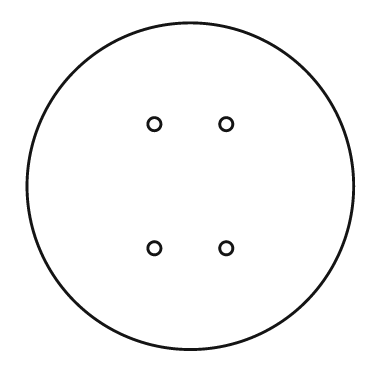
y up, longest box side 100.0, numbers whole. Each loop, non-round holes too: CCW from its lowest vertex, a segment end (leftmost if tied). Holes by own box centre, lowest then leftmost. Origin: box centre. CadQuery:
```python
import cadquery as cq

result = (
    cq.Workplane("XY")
    .moveTo(0.0, 0.0)
    .circle(50.0)
    .moveTo(-11.0, -19.0)
    .circle(2.0)
    .moveTo(11.0, -19.0)
    .circle(2.0)
    .moveTo(-11.0, 19.0)
    .circle(2.0)
    .moveTo(11.0, 19.0)
    .circle(2.0)
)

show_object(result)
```